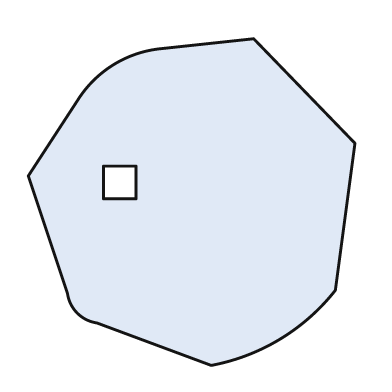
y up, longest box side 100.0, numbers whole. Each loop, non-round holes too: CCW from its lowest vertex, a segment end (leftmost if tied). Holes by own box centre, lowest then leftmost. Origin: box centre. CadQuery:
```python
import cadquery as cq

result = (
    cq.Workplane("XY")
    .moveTo(6.0, -50.0)
    .threePointArc((27.0, -42.0), (44.0, -27.0))
    .lineTo(50.0, 18.0)
    .lineTo(19.0, 50.0)
    .lineTo(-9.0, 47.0)
    .threePointArc((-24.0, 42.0), (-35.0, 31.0))
    .lineTo(-50.0, 8.0)
    .lineTo(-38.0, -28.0)
    .threePointArc((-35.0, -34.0), (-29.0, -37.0))
    .close()
    .moveTo(-27.0, 1.0)
    .lineTo(-17.0, 1.0)
    .lineTo(-17.0, 11.0)
    .lineTo(-27.0, 11.0)
    .close()
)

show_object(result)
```